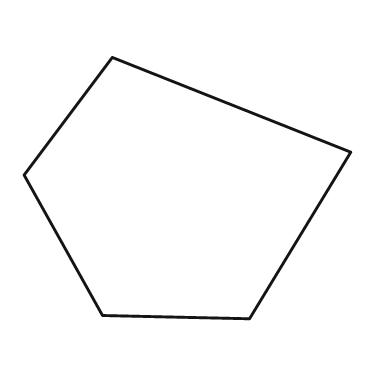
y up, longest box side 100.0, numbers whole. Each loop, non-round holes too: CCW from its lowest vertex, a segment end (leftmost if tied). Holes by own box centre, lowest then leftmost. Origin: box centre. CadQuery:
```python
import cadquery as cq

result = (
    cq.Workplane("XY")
    .moveTo(19.0, -40.0)
    .lineTo(50.0, 11.0)
    .lineTo(-23.0, 40.0)
    .lineTo(-50.0, 4.0)
    .lineTo(-26.0, -39.0)
    .close()
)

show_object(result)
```